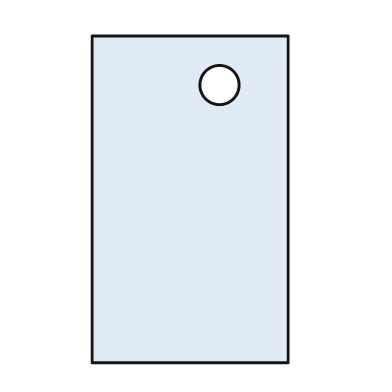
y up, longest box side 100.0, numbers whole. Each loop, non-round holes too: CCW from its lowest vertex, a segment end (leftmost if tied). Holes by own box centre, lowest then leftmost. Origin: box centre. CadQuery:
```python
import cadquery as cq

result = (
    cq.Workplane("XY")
    .moveTo(-30.0, -50.0)
    .lineTo(30.0, -50.0)
    .lineTo(30.0, 50.0)
    .lineTo(-30.0, 50.0)
    .close()
    .moveTo(9.0, 35.0)
    .circle(6.0)
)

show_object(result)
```